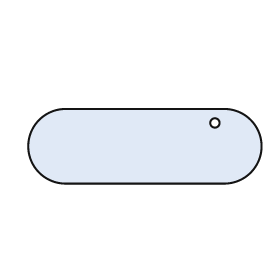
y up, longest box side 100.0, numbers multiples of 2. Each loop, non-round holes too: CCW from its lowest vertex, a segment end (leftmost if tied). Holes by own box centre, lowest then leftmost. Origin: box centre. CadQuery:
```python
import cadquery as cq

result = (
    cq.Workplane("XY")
    .moveTo(-34.0, -16.0)
    .lineTo(34.0, -16.0)
    .threePointArc((50.0, 0.0), (34.0, 16.0))
    .lineTo(-34.0, 16.0)
    .threePointArc((-50.0, 0.0), (-34.0, -16.0))
    .close()
    .moveTo(30.0, 10.0)
    .circle(2.0)
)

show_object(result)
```